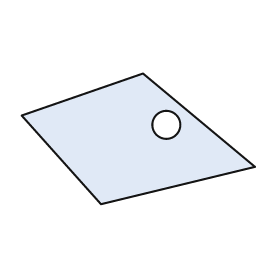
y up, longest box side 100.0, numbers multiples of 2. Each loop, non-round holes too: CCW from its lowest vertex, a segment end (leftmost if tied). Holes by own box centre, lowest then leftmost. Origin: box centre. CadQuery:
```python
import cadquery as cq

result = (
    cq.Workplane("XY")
    .moveTo(-16.0, -28.0)
    .lineTo(50.0, -12.0)
    .lineTo(2.0, 28.0)
    .lineTo(-50.0, 10.0)
    .close()
    .moveTo(12.0, 6.0)
    .circle(6.0)
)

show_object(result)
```